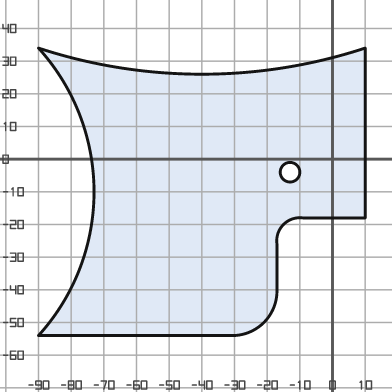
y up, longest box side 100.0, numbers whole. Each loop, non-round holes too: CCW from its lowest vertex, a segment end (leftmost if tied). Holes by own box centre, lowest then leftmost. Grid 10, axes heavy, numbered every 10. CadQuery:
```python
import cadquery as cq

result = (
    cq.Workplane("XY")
    .moveTo(-90.0, -54.0)
    .lineTo(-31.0, -54.0)
    .threePointArc((-21.0, -50.0), (-17.0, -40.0))
    .lineTo(-17.0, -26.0)
    .threePointArc((-15.0, -20.0), (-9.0, -18.0))
    .lineTo(10.0, -18.0)
    .lineTo(10.0, 34.0)
    .threePointArc((-40.0, 26.0), (-90.0, 34.0))
    .threePointArc((-73.0, -10.0), (-90.0, -54.0))
    .close()
    .moveTo(-13.0, -4.0)
    .circle(3.0)
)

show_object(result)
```